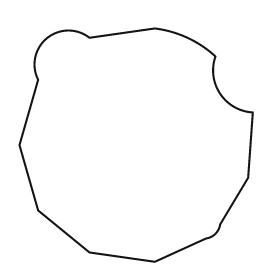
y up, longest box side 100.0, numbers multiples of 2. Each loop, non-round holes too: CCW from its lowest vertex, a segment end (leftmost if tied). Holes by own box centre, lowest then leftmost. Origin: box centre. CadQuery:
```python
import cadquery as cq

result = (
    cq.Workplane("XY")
    .moveTo(8.0, -50.0)
    .lineTo(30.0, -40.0)
    .threePointArc((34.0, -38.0), (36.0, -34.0))
    .lineTo(48.0, -14.0)
    .lineTo(50.0, 14.0)
    .threePointArc((36.0, 22.0), (34.0, 38.0))
    .threePointArc((22.0, 46.0), (8.0, 50.0))
    .lineTo(-20.0, 46.0)
    .threePointArc((-38.0, 46.0), (-42.0, 28.0))
    .lineTo(-50.0, 0.0)
    .lineTo(-42.0, -28.0)
    .lineTo(-20.0, -46.0)
    .close()
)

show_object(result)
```